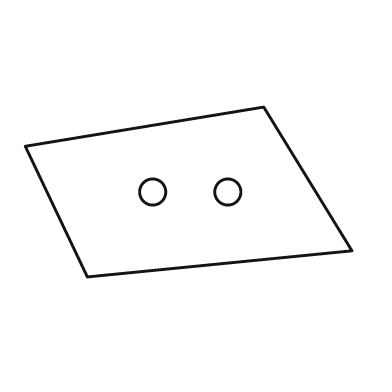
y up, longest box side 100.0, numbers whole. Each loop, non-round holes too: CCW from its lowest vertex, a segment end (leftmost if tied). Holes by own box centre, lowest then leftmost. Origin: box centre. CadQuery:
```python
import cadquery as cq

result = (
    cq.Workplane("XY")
    .moveTo(-31.0, -26.0)
    .lineTo(50.0, -18.0)
    .lineTo(23.0, 26.0)
    .lineTo(-50.0, 14.0)
    .close()
    .moveTo(-11.0, 0.0)
    .circle(4.0)
    .moveTo(12.0, 0.0)
    .circle(4.0)
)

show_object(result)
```